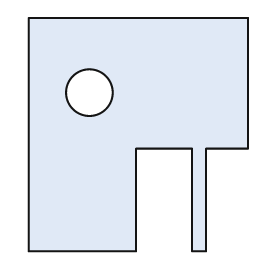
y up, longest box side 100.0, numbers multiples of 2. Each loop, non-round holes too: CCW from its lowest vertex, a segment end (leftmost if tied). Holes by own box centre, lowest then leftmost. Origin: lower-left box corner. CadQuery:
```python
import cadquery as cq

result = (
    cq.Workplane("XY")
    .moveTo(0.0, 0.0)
    .lineTo(46.0, 0.0)
    .lineTo(46.0, 44.0)
    .lineTo(70.0, 44.0)
    .lineTo(70.0, 0.0)
    .lineTo(76.0, 0.0)
    .lineTo(76.0, 44.0)
    .lineTo(94.0, 44.0)
    .lineTo(94.0, 100.0)
    .lineTo(0.0, 100.0)
    .close()
    .moveTo(26.0, 68.0)
    .circle(10.0)
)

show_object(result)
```